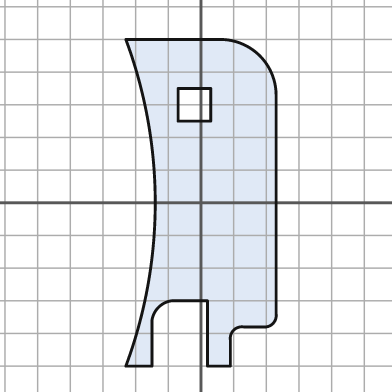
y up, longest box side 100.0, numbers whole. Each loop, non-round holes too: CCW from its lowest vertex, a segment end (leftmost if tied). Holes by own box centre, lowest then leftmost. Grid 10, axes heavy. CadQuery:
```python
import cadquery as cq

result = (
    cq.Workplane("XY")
    .moveTo(-23.0, -50.0)
    .lineTo(-15.0, -50.0)
    .lineTo(-15.0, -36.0)
    .threePointArc((-13.0, -32.0), (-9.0, -30.0))
    .lineTo(2.0, -30.0)
    .lineTo(2.0, -50.0)
    .lineTo(9.0, -50.0)
    .lineTo(9.0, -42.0)
    .threePointArc((10.0, -39.0), (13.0, -38.0))
    .lineTo(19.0, -38.0)
    .threePointArc((22.0, -37.0), (23.0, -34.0))
    .lineTo(23.0, 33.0)
    .threePointArc((18.0, 45.0), (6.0, 50.0))
    .lineTo(-23.0, 50.0)
    .threePointArc((-14.0, 0.0), (-23.0, -50.0))
    .close()
    .moveTo(-7.0, 25.0)
    .lineTo(3.0, 25.0)
    .lineTo(3.0, 35.0)
    .lineTo(-7.0, 35.0)
    .close()
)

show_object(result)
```